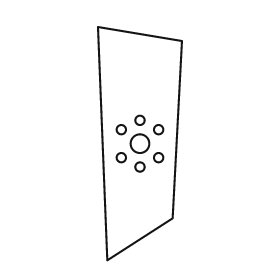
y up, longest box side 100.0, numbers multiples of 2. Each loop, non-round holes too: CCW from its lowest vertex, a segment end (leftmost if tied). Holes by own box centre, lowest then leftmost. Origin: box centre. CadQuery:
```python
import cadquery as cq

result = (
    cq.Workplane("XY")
    .moveTo(-14.0, -50.0)
    .lineTo(14.0, -32.0)
    .lineTo(18.0, 44.0)
    .lineTo(-18.0, 50.0)
    .close()
    .moveTo(0.0, -10.0)
    .circle(2.0)
    .moveTo(-8.0, -6.0)
    .circle(2.0)
    .moveTo(8.0, -6.0)
    .circle(2.0)
    .moveTo(0.0, 0.0)
    .circle(4.0)
    .moveTo(-8.0, 6.0)
    .circle(2.0)
    .moveTo(8.0, 6.0)
    .circle(2.0)
    .moveTo(0.0, 10.0)
    .circle(2.0)
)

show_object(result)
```